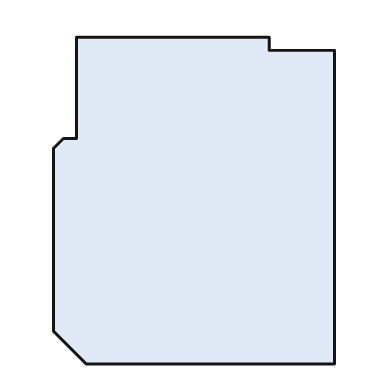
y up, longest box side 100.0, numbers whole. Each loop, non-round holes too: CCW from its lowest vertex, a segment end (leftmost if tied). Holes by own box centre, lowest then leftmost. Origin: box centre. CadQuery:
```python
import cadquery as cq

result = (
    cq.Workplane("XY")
    .moveTo(-33.0, -50.0)
    .lineTo(43.0, -50.0)
    .lineTo(43.0, 46.0)
    .lineTo(23.0, 46.0)
    .lineTo(23.0, 50.0)
    .lineTo(-36.0, 50.0)
    .lineTo(-36.0, 19.0)
    .lineTo(-40.0, 19.0)
    .lineTo(-43.0, 16.0)
    .lineTo(-43.0, -40.0)
    .close()
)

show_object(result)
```